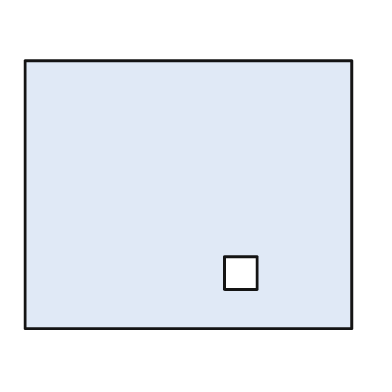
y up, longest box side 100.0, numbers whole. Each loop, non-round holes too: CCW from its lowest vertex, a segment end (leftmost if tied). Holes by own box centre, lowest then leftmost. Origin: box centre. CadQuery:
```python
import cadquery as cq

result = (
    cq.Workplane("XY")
    .moveTo(-50.0, -41.0)
    .lineTo(50.0, -41.0)
    .lineTo(50.0, 41.0)
    .lineTo(-50.0, 41.0)
    .close()
    .moveTo(11.0, -29.0)
    .lineTo(21.0, -29.0)
    .lineTo(21.0, -19.0)
    .lineTo(11.0, -19.0)
    .close()
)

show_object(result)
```